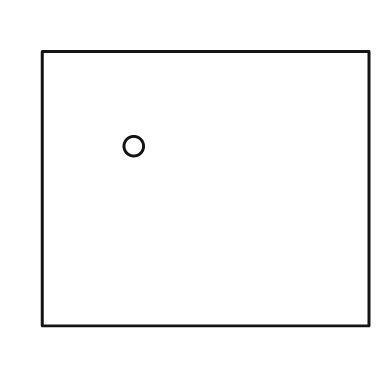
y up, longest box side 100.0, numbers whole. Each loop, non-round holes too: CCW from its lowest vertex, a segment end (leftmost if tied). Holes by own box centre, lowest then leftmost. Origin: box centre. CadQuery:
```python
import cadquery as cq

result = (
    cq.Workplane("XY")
    .moveTo(-50.0, -42.0)
    .lineTo(50.0, -42.0)
    .lineTo(50.0, 42.0)
    .lineTo(-50.0, 42.0)
    .close()
    .moveTo(-22.0, 13.0)
    .circle(3.0)
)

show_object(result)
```